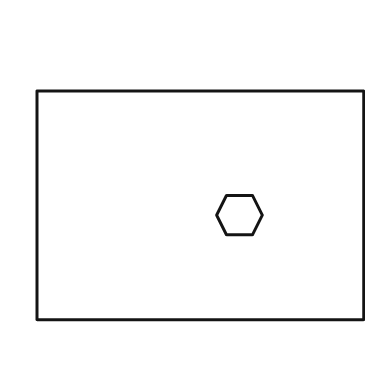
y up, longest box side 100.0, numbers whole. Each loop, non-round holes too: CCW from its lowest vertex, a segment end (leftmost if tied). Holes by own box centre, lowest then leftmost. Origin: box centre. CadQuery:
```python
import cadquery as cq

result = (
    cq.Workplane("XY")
    .moveTo(-50.0, -35.0)
    .lineTo(50.0, -35.0)
    .lineTo(50.0, 35.0)
    .lineTo(-50.0, 35.0)
    .close()
    .moveTo(8.0, -9.0)
    .lineTo(16.0, -9.0)
    .lineTo(19.0, -3.0)
    .lineTo(16.0, 3.0)
    .lineTo(8.0, 3.0)
    .lineTo(5.0, -3.0)
    .close()
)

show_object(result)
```